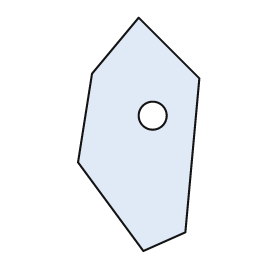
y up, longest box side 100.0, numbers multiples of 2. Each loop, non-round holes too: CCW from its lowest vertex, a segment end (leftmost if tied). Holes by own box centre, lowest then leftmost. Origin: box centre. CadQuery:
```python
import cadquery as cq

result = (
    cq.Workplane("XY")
    .moveTo(2.0, -50.0)
    .lineTo(20.0, -42.0)
    .lineTo(26.0, 24.0)
    .lineTo(0.0, 50.0)
    .lineTo(-20.0, 26.0)
    .lineTo(-26.0, -12.0)
    .close()
    .moveTo(6.0, 8.0)
    .circle(6.0)
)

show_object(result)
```